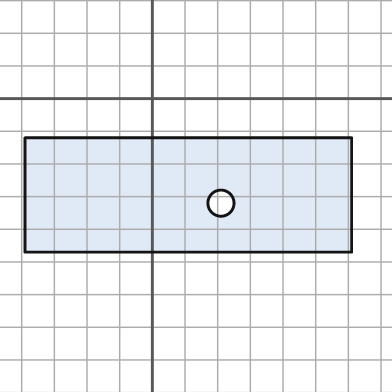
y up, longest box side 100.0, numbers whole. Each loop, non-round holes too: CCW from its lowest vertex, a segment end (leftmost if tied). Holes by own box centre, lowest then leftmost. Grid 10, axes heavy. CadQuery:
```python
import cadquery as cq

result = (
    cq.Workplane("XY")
    .moveTo(-39.0, -47.0)
    .lineTo(61.0, -47.0)
    .lineTo(61.0, -12.0)
    .lineTo(-39.0, -12.0)
    .close()
    .moveTo(21.0, -32.0)
    .circle(4.0)
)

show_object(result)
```